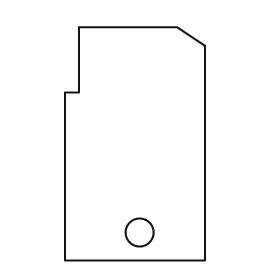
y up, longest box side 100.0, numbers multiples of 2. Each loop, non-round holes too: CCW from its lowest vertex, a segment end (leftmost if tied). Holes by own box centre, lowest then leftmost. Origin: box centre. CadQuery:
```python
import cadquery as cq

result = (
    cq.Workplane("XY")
    .moveTo(-30.0, -50.0)
    .lineTo(30.0, -50.0)
    .lineTo(30.0, 42.0)
    .lineTo(18.0, 50.0)
    .lineTo(-24.0, 50.0)
    .lineTo(-24.0, 22.0)
    .lineTo(-30.0, 22.0)
    .close()
    .moveTo(2.0, -38.0)
    .circle(6.0)
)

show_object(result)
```